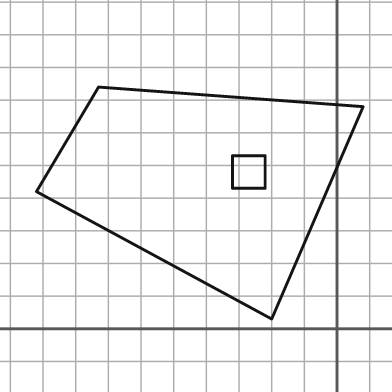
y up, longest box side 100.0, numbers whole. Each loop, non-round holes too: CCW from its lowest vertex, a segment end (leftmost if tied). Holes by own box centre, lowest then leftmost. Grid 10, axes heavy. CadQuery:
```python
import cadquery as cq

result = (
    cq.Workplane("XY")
    .moveTo(-20.0, 3.0)
    .lineTo(8.0, 68.0)
    .lineTo(-73.0, 74.0)
    .lineTo(-92.0, 42.0)
    .close()
    .moveTo(-32.0, 43.0)
    .lineTo(-22.0, 43.0)
    .lineTo(-22.0, 53.0)
    .lineTo(-32.0, 53.0)
    .close()
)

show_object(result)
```